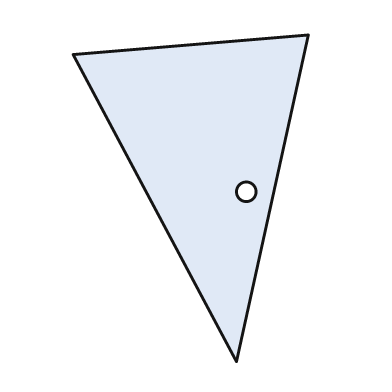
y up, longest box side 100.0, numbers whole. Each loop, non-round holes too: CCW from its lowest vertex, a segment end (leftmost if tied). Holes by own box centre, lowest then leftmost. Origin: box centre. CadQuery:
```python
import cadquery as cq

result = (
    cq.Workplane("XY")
    .moveTo(14.0, -50.0)
    .lineTo(36.0, 50.0)
    .lineTo(-36.0, 44.0)
    .close()
    .moveTo(17.0, 2.0)
    .circle(3.0)
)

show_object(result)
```